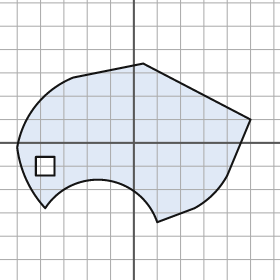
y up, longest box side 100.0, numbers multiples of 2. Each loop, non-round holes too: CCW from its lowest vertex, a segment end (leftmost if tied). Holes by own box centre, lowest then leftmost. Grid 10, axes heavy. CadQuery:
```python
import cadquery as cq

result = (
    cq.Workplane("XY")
    .moveTo(10.0, -34.0)
    .lineTo(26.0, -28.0)
    .threePointArc((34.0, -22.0), (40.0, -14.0))
    .lineTo(50.0, 10.0)
    .lineTo(4.0, 34.0)
    .lineTo(-26.0, 28.0)
    .threePointArc((-42.0, 16.0), (-50.0, -2.0))
    .threePointArc((-46.0, -16.0), (-38.0, -28.0))
    .threePointArc((-12.0, -16.0), (10.0, -34.0))
    .close()
    .moveTo(-42.0, -14.0)
    .lineTo(-34.0, -14.0)
    .lineTo(-34.0, -6.0)
    .lineTo(-42.0, -6.0)
    .close()
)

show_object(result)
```